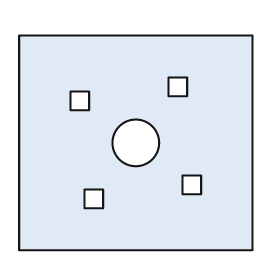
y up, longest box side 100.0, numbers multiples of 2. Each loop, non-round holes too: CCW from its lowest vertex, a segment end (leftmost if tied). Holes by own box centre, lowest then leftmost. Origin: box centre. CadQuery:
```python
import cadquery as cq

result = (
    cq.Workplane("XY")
    .moveTo(-50.0, -46.0)
    .lineTo(50.0, -46.0)
    .lineTo(50.0, 46.0)
    .lineTo(-50.0, 46.0)
    .close()
    .moveTo(-22.0, -28.0)
    .lineTo(-14.0, -28.0)
    .lineTo(-14.0, -20.0)
    .lineTo(-22.0, -20.0)
    .close()
    .moveTo(20.0, -22.0)
    .lineTo(28.0, -22.0)
    .lineTo(28.0, -14.0)
    .lineTo(20.0, -14.0)
    .close()
    .moveTo(0.0, 0.0)
    .circle(10.0)
    .moveTo(-28.0, 14.0)
    .lineTo(-20.0, 14.0)
    .lineTo(-20.0, 22.0)
    .lineTo(-28.0, 22.0)
    .close()
    .moveTo(14.0, 20.0)
    .lineTo(22.0, 20.0)
    .lineTo(22.0, 28.0)
    .lineTo(14.0, 28.0)
    .close()
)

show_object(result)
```